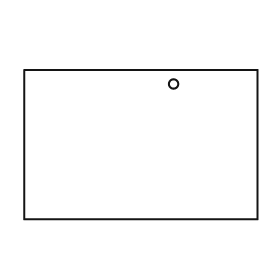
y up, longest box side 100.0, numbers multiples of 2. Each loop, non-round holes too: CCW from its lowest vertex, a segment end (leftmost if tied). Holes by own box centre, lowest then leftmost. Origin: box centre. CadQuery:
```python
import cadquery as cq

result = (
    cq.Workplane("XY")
    .moveTo(-50.0, -32.0)
    .lineTo(50.0, -32.0)
    .lineTo(50.0, 32.0)
    .lineTo(-50.0, 32.0)
    .close()
    .moveTo(14.0, 26.0)
    .circle(2.0)
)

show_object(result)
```